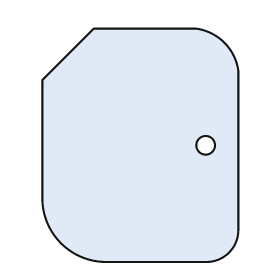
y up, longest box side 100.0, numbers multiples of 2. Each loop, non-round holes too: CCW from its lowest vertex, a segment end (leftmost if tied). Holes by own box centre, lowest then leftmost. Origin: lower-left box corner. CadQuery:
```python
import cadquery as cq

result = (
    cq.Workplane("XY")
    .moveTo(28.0, 0.0)
    .lineTo(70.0, 0.0)
    .threePointArc((80.0, 4.0), (84.0, 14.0))
    .lineTo(84.0, 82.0)
    .threePointArc((78.0, 94.0), (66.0, 100.0))
    .lineTo(22.0, 100.0)
    .lineTo(0.0, 78.0)
    .lineTo(0.0, 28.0)
    .threePointArc((8.0, 8.0), (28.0, 0.0))
    .close()
    .moveTo(70.0, 50.0)
    .circle(4.0)
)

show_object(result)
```